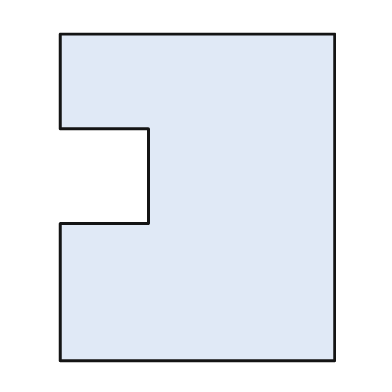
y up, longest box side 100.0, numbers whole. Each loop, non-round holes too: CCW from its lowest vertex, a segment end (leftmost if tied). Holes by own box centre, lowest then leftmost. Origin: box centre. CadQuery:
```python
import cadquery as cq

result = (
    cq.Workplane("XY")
    .moveTo(-42.0, -50.0)
    .lineTo(42.0, -50.0)
    .lineTo(42.0, 50.0)
    .lineTo(-42.0, 50.0)
    .lineTo(-42.0, 21.0)
    .lineTo(-15.0, 21.0)
    .lineTo(-15.0, -8.0)
    .lineTo(-42.0, -8.0)
    .close()
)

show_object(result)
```